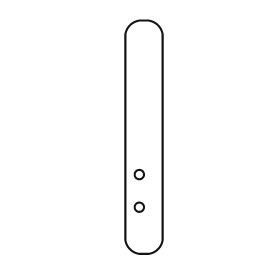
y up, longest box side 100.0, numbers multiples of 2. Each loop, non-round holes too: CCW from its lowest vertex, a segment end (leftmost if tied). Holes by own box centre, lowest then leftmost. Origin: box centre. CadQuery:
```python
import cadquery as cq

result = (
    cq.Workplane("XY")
    .moveTo(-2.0, -50.0)
    .lineTo(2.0, -50.0)
    .threePointArc((6.0, -48.0), (8.0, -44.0))
    .lineTo(8.0, 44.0)
    .threePointArc((6.0, 48.0), (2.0, 50.0))
    .lineTo(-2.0, 50.0)
    .threePointArc((-6.0, 48.0), (-8.0, 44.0))
    .lineTo(-8.0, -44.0)
    .threePointArc((-6.0, -48.0), (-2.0, -50.0))
    .close()
    .moveTo(-2.0, -30.0)
    .circle(2.0)
    .moveTo(-2.0, -16.0)
    .circle(2.0)
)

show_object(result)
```